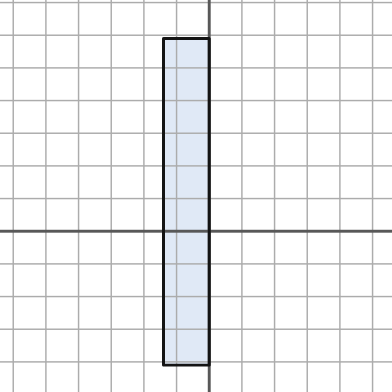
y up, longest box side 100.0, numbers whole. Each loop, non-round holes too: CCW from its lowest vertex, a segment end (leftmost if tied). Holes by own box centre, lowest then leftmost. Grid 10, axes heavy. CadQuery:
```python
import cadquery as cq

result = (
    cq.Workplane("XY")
    .moveTo(-14.0, -41.0)
    .lineTo(0.0, -41.0)
    .lineTo(0.0, 59.0)
    .lineTo(-14.0, 59.0)
    .close()
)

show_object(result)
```